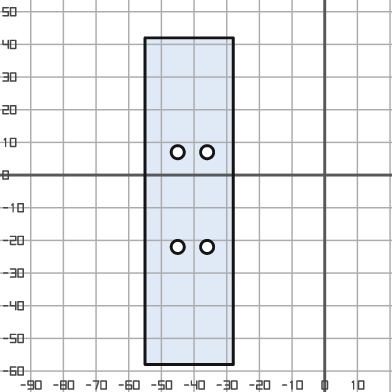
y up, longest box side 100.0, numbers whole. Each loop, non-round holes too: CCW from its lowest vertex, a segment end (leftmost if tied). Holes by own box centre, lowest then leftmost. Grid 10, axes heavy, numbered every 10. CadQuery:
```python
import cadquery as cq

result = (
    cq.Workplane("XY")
    .moveTo(-55.0, -58.0)
    .lineTo(-28.0, -58.0)
    .lineTo(-28.0, 42.0)
    .lineTo(-55.0, 42.0)
    .close()
    .moveTo(-45.0, -22.0)
    .circle(2.0)
    .moveTo(-36.0, -22.0)
    .circle(2.0)
    .moveTo(-45.0, 7.0)
    .circle(2.0)
    .moveTo(-36.0, 7.0)
    .circle(2.0)
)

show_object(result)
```